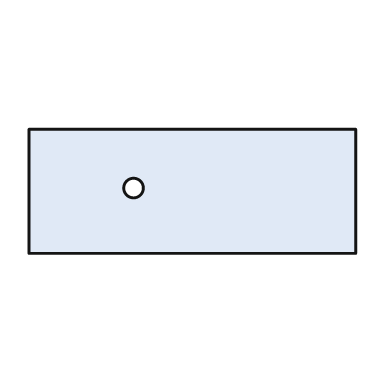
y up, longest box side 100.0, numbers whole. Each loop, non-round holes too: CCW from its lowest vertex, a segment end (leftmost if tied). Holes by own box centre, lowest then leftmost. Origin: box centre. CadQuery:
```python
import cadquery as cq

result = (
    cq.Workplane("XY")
    .moveTo(-50.0, -19.0)
    .lineTo(50.0, -19.0)
    .lineTo(50.0, 19.0)
    .lineTo(-50.0, 19.0)
    .close()
    .moveTo(-18.0, 1.0)
    .circle(3.0)
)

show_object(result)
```